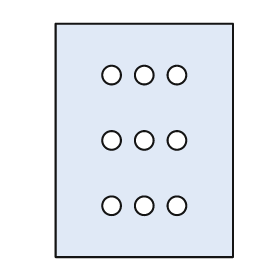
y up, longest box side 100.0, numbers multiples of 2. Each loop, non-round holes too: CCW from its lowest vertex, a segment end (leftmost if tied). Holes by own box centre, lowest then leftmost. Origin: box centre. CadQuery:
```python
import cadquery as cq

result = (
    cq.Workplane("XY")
    .moveTo(-38.0, -50.0)
    .lineTo(38.0, -50.0)
    .lineTo(38.0, 50.0)
    .lineTo(-38.0, 50.0)
    .close()
    .moveTo(-14.0, -28.0)
    .circle(4.0)
    .moveTo(0.0, -28.0)
    .circle(4.0)
    .moveTo(14.0, -28.0)
    .circle(4.0)
    .moveTo(-14.0, 0.0)
    .circle(4.0)
    .moveTo(0.0, 0.0)
    .circle(4.0)
    .moveTo(14.0, 0.0)
    .circle(4.0)
    .moveTo(-14.0, 28.0)
    .circle(4.0)
    .moveTo(0.0, 28.0)
    .circle(4.0)
    .moveTo(14.0, 28.0)
    .circle(4.0)
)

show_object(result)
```